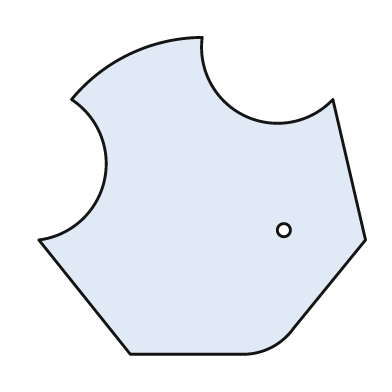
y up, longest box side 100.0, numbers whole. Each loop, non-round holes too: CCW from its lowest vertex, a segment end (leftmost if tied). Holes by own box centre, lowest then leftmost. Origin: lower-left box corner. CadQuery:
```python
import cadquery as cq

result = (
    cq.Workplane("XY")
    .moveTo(28.0, 0.0)
    .lineTo(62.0, 0.0)
    .threePointArc((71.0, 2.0), (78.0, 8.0))
    .lineTo(100.0, 35.0)
    .lineTo(90.0, 78.0)
    .threePointArc((63.0, 73.0), (50.0, 97.0))
    .threePointArc((28.0, 92.0), (10.0, 78.0))
    .threePointArc((20.0, 53.0), (0.0, 35.0))
    .close()
    .moveTo(75.0, 38.0)
    .circle(2.0)
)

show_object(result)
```